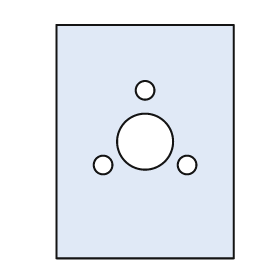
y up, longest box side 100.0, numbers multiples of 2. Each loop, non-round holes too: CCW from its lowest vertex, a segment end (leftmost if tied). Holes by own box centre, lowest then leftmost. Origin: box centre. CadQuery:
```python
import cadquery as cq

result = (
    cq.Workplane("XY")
    .moveTo(-38.0, -50.0)
    .lineTo(38.0, -50.0)
    .lineTo(38.0, 50.0)
    .lineTo(-38.0, 50.0)
    .close()
    .moveTo(-18.0, -10.0)
    .circle(4.0)
    .moveTo(18.0, -10.0)
    .circle(4.0)
    .moveTo(0.0, 0.0)
    .circle(12.0)
    .moveTo(0.0, 22.0)
    .circle(4.0)
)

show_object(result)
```